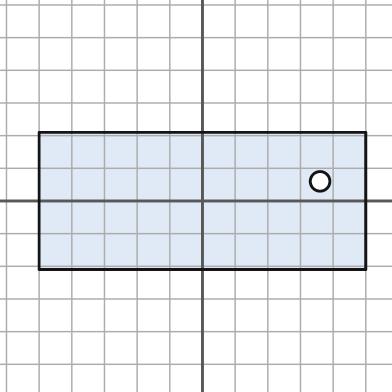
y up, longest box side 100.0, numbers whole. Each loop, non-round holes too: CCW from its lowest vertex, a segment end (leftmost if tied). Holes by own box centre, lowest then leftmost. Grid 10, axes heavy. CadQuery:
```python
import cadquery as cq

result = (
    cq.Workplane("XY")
    .moveTo(-50.0, -21.0)
    .lineTo(50.0, -21.0)
    .lineTo(50.0, 21.0)
    .lineTo(-50.0, 21.0)
    .close()
    .moveTo(36.0, 6.0)
    .circle(3.0)
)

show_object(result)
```